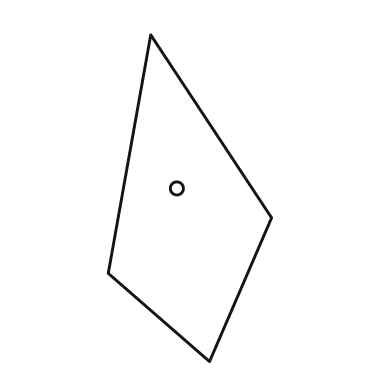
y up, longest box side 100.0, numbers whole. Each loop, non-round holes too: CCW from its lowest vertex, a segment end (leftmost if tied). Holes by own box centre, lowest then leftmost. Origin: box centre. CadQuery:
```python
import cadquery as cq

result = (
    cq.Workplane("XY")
    .moveTo(6.0, -50.0)
    .lineTo(25.0, -6.0)
    .lineTo(-12.0, 50.0)
    .lineTo(-25.0, -23.0)
    .close()
    .moveTo(-4.0, 3.0)
    .circle(2.0)
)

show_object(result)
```